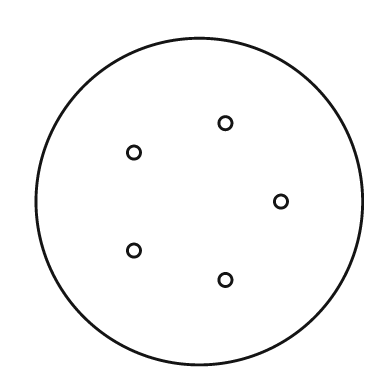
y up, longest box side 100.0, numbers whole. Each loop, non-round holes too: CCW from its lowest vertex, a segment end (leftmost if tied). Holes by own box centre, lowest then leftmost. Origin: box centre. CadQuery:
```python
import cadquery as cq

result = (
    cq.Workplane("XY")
    .moveTo(0.0, 0.0)
    .circle(50.0)
    .moveTo(8.0, -24.0)
    .circle(2.0)
    .moveTo(-20.0, -15.0)
    .circle(2.0)
    .moveTo(25.0, 0.0)
    .circle(2.0)
    .moveTo(-20.0, 15.0)
    .circle(2.0)
    .moveTo(8.0, 24.0)
    .circle(2.0)
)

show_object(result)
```